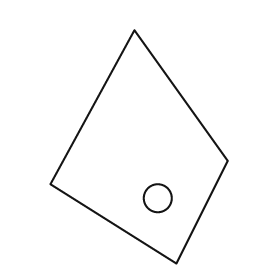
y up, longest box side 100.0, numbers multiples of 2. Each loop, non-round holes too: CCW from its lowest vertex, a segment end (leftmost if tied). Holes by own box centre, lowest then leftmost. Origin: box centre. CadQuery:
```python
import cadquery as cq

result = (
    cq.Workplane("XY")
    .moveTo(16.0, -50.0)
    .lineTo(38.0, -6.0)
    .lineTo(-2.0, 50.0)
    .lineTo(-38.0, -16.0)
    .close()
    .moveTo(8.0, -22.0)
    .circle(6.0)
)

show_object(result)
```